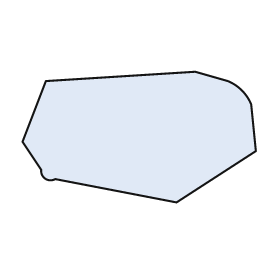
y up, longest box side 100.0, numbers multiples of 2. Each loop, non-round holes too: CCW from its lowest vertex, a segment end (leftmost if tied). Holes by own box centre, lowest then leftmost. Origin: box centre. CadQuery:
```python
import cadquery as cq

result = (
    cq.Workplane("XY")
    .moveTo(16.0, -28.0)
    .lineTo(50.0, -6.0)
    .lineTo(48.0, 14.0)
    .threePointArc((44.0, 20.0), (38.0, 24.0))
    .lineTo(24.0, 28.0)
    .lineTo(-40.0, 24.0)
    .lineTo(-50.0, -2.0)
    .lineTo(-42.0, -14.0)
    .threePointArc((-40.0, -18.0), (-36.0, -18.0))
    .close()
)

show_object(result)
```